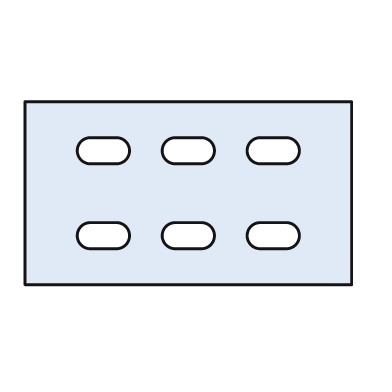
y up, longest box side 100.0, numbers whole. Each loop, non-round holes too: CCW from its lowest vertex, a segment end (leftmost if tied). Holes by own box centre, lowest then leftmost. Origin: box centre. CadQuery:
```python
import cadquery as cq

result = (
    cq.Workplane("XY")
    .moveTo(-50.0, -28.0)
    .lineTo(50.0, -28.0)
    .lineTo(50.0, 28.0)
    .lineTo(-50.0, 28.0)
    .close()
    .moveTo(-30.0, -17.0)
    .lineTo(-22.0, -17.0)
    .threePointArc((-18.0, -13.0), (-22.0, -9.0))
    .lineTo(-30.0, -9.0)
    .threePointArc((-34.0, -13.0), (-30.0, -17.0))
    .close()
    .moveTo(-4.0, -17.0)
    .lineTo(4.0, -17.0)
    .threePointArc((8.0, -13.0), (4.0, -9.0))
    .lineTo(-4.0, -9.0)
    .threePointArc((-8.0, -13.0), (-4.0, -17.0))
    .close()
    .moveTo(22.0, -17.0)
    .lineTo(30.0, -17.0)
    .threePointArc((34.0, -13.0), (30.0, -9.0))
    .lineTo(22.0, -9.0)
    .threePointArc((18.0, -13.0), (22.0, -17.0))
    .close()
    .moveTo(-30.0, 9.0)
    .lineTo(-22.0, 9.0)
    .threePointArc((-18.0, 13.0), (-22.0, 17.0))
    .lineTo(-30.0, 17.0)
    .threePointArc((-34.0, 13.0), (-30.0, 9.0))
    .close()
    .moveTo(-4.0, 9.0)
    .lineTo(4.0, 9.0)
    .threePointArc((8.0, 13.0), (4.0, 17.0))
    .lineTo(-4.0, 17.0)
    .threePointArc((-8.0, 13.0), (-4.0, 9.0))
    .close()
    .moveTo(22.0, 9.0)
    .lineTo(30.0, 9.0)
    .threePointArc((34.0, 13.0), (30.0, 17.0))
    .lineTo(22.0, 17.0)
    .threePointArc((18.0, 13.0), (22.0, 9.0))
    .close()
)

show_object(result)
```